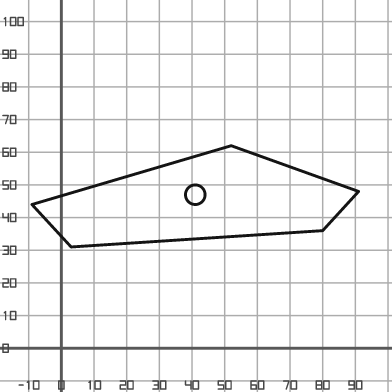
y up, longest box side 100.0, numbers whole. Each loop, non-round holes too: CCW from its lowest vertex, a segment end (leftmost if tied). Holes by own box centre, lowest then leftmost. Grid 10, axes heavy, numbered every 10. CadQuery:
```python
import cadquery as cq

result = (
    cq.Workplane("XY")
    .moveTo(3.0, 31.0)
    .lineTo(80.0, 36.0)
    .lineTo(91.0, 48.0)
    .lineTo(52.0, 62.0)
    .lineTo(-9.0, 44.0)
    .close()
    .moveTo(41.0, 47.0)
    .circle(3.0)
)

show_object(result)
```